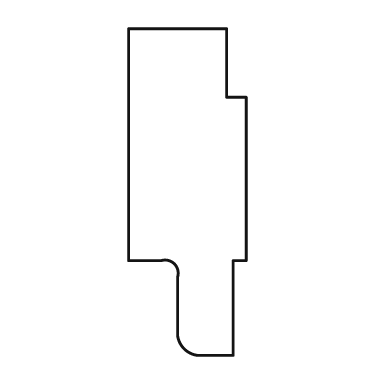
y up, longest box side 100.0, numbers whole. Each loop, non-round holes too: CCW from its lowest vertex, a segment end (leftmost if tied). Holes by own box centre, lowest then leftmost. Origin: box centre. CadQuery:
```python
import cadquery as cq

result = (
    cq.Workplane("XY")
    .moveTo(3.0, -50.0)
    .lineTo(14.0, -50.0)
    .lineTo(14.0, -21.0)
    .lineTo(18.0, -21.0)
    .lineTo(18.0, 29.0)
    .lineTo(12.0, 29.0)
    .lineTo(12.0, 50.0)
    .lineTo(-18.0, 50.0)
    .lineTo(-18.0, -21.0)
    .lineTo(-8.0, -21.0)
    .threePointArc((-4.0, -22.0), (-3.0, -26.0))
    .lineTo(-3.0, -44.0)
    .threePointArc((-1.0, -48.0), (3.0, -50.0))
    .close()
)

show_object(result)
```